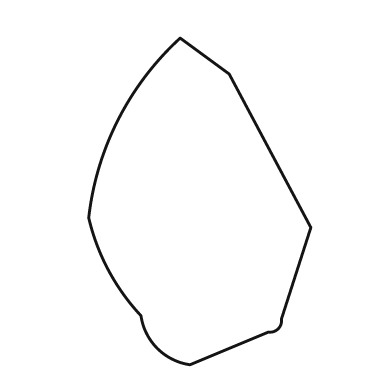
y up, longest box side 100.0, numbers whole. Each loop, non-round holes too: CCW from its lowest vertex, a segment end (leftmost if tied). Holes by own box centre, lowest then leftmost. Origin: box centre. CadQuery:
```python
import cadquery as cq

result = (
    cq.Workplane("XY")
    .moveTo(-3.0, -50.0)
    .lineTo(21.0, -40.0)
    .threePointArc((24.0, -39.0), (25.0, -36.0))
    .lineTo(34.0, -8.0)
    .lineTo(9.0, 39.0)
    .lineTo(-6.0, 50.0)
    .threePointArc((-25.0, 25.0), (-34.0, -5.0))
    .threePointArc((-28.0, -21.0), (-18.0, -35.0))
    .threePointArc((-13.0, -45.0), (-3.0, -50.0))
    .close()
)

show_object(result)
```